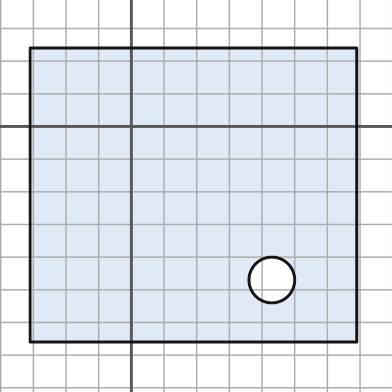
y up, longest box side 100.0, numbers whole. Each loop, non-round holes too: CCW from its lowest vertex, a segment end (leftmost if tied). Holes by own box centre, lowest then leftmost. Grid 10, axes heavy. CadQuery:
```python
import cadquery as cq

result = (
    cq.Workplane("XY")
    .moveTo(-31.0, -66.0)
    .lineTo(69.0, -66.0)
    .lineTo(69.0, 24.0)
    .lineTo(-31.0, 24.0)
    .close()
    .moveTo(43.0, -47.0)
    .circle(7.0)
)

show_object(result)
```